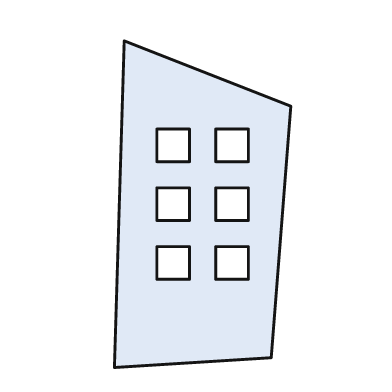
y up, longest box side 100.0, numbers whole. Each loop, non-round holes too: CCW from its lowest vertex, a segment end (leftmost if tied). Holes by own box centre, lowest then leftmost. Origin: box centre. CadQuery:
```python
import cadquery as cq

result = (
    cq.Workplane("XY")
    .moveTo(-27.0, -50.0)
    .lineTo(21.0, -47.0)
    .lineTo(27.0, 30.0)
    .lineTo(-24.0, 50.0)
    .close()
    .moveTo(-14.0, -23.0)
    .lineTo(-4.0, -23.0)
    .lineTo(-4.0, -13.0)
    .lineTo(-14.0, -13.0)
    .close()
    .moveTo(4.0, -23.0)
    .lineTo(14.0, -23.0)
    .lineTo(14.0, -13.0)
    .lineTo(4.0, -13.0)
    .close()
    .moveTo(-14.0, -5.0)
    .lineTo(-4.0, -5.0)
    .lineTo(-4.0, 5.0)
    .lineTo(-14.0, 5.0)
    .close()
    .moveTo(4.0, -5.0)
    .lineTo(14.0, -5.0)
    .lineTo(14.0, 5.0)
    .lineTo(4.0, 5.0)
    .close()
    .moveTo(-14.0, 13.0)
    .lineTo(-4.0, 13.0)
    .lineTo(-4.0, 23.0)
    .lineTo(-14.0, 23.0)
    .close()
    .moveTo(4.0, 13.0)
    .lineTo(14.0, 13.0)
    .lineTo(14.0, 23.0)
    .lineTo(4.0, 23.0)
    .close()
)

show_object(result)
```